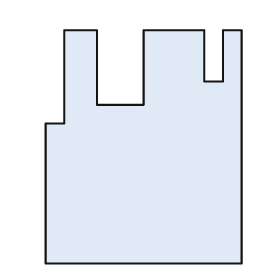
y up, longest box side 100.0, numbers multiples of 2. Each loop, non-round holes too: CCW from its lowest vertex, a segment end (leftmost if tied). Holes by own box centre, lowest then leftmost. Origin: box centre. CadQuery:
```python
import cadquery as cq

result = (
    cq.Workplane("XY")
    .moveTo(-42.0, -50.0)
    .lineTo(42.0, -50.0)
    .lineTo(42.0, 50.0)
    .lineTo(34.0, 50.0)
    .lineTo(34.0, 28.0)
    .lineTo(26.0, 28.0)
    .lineTo(26.0, 50.0)
    .lineTo(0.0, 50.0)
    .lineTo(0.0, 18.0)
    .lineTo(-20.0, 18.0)
    .lineTo(-20.0, 50.0)
    .lineTo(-34.0, 50.0)
    .lineTo(-34.0, 10.0)
    .lineTo(-42.0, 10.0)
    .close()
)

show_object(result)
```